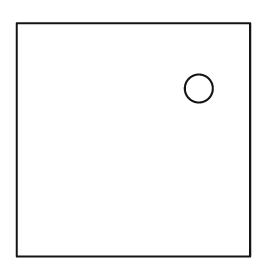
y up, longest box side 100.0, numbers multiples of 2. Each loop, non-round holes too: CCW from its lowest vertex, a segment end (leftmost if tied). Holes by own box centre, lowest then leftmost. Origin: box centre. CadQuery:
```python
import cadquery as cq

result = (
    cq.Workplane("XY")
    .moveTo(-50.0, -50.0)
    .lineTo(50.0, -50.0)
    .lineTo(50.0, 50.0)
    .lineTo(-50.0, 50.0)
    .close()
    .moveTo(28.0, 22.0)
    .circle(6.0)
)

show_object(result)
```